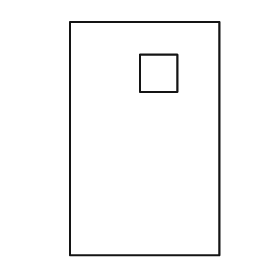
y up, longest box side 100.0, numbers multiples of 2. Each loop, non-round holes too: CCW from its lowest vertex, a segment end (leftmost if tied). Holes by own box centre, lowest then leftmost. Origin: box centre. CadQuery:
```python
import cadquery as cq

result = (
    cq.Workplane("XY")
    .moveTo(-32.0, -50.0)
    .lineTo(32.0, -50.0)
    .lineTo(32.0, 50.0)
    .lineTo(-32.0, 50.0)
    .close()
    .moveTo(-2.0, 20.0)
    .lineTo(14.0, 20.0)
    .lineTo(14.0, 36.0)
    .lineTo(-2.0, 36.0)
    .close()
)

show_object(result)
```